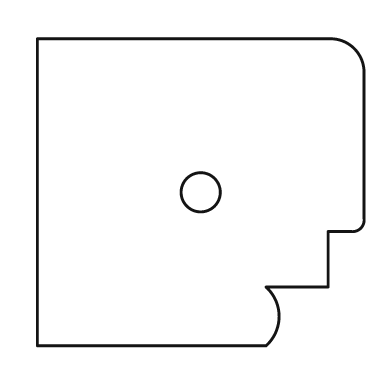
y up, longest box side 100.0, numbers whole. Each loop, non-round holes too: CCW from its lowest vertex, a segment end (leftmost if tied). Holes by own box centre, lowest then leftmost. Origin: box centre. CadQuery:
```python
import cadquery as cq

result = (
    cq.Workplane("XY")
    .moveTo(-50.0, -47.0)
    .lineTo(20.0, -47.0)
    .threePointArc((24.0, -38.0), (20.0, -29.0))
    .lineTo(39.0, -29.0)
    .lineTo(39.0, -12.0)
    .lineTo(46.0, -12.0)
    .threePointArc((49.0, -11.0), (50.0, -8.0))
    .lineTo(50.0, 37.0)
    .threePointArc((47.0, 44.0), (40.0, 47.0))
    .lineTo(-50.0, 47.0)
    .close()
    .moveTo(0.0, 0.0)
    .circle(6.0)
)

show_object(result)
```